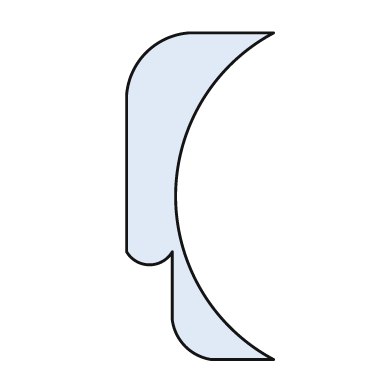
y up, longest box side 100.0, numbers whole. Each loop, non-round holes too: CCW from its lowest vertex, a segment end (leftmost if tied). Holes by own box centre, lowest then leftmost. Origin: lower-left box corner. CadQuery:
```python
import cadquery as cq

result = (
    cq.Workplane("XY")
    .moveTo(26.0, 0.0)
    .lineTo(45.0, 0.0)
    .threePointArc((15.0, 50.0), (45.0, 100.0))
    .lineTo(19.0, 100.0)
    .threePointArc((6.0, 94.0), (0.0, 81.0))
    .lineTo(0.0, 33.0)
    .threePointArc((7.0, 29.0), (14.0, 33.0))
    .lineTo(14.0, 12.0)
    .threePointArc((18.0, 4.0), (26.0, 0.0))
    .close()
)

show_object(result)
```